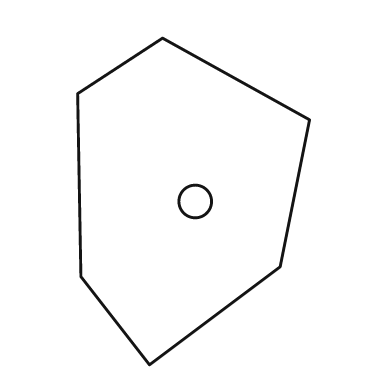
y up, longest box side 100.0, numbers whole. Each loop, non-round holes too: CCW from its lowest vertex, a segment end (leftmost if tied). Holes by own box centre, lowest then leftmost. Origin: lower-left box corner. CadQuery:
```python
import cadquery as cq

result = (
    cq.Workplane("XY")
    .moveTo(22.0, 0.0)
    .lineTo(62.0, 30.0)
    .lineTo(71.0, 75.0)
    .lineTo(26.0, 100.0)
    .lineTo(0.0, 83.0)
    .lineTo(1.0, 27.0)
    .close()
    .moveTo(36.0, 50.0)
    .circle(5.0)
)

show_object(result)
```